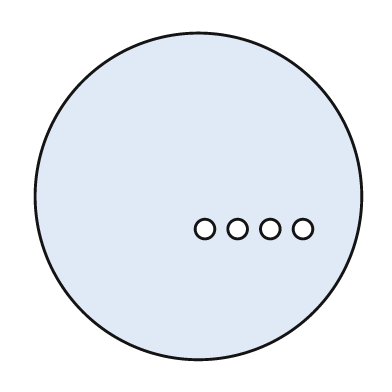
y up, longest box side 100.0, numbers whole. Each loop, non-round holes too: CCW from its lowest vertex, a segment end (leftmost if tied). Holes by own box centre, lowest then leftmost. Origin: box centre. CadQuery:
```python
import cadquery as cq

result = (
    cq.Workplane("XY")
    .moveTo(0.0, 0.0)
    .circle(50.0)
    .moveTo(2.0, -10.0)
    .circle(3.0)
    .moveTo(12.0, -10.0)
    .circle(3.0)
    .moveTo(22.0, -10.0)
    .circle(3.0)
    .moveTo(32.0, -10.0)
    .circle(3.0)
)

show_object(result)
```